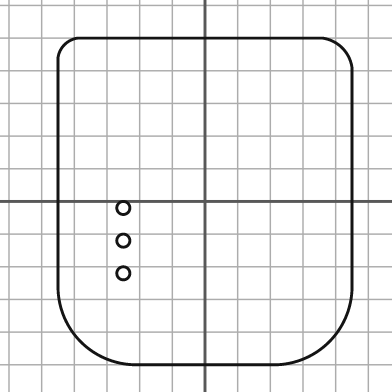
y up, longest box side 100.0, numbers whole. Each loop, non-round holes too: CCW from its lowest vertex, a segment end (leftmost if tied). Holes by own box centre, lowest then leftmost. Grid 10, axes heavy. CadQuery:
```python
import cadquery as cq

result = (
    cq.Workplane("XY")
    .moveTo(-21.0, -50.0)
    .lineTo(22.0, -50.0)
    .threePointArc((38.0, -43.0), (45.0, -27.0))
    .lineTo(45.0, 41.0)
    .threePointArc((42.0, 47.0), (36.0, 50.0))
    .lineTo(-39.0, 50.0)
    .threePointArc((-43.0, 48.0), (-45.0, 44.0))
    .lineTo(-45.0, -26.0)
    .threePointArc((-38.0, -43.0), (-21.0, -50.0))
    .close()
    .moveTo(-25.0, -22.0)
    .circle(2.0)
    .moveTo(-25.0, -12.0)
    .circle(2.0)
    .moveTo(-25.0, -2.0)
    .circle(2.0)
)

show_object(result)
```